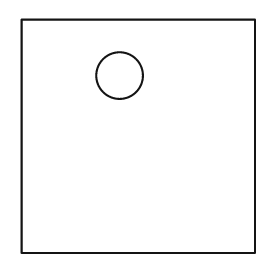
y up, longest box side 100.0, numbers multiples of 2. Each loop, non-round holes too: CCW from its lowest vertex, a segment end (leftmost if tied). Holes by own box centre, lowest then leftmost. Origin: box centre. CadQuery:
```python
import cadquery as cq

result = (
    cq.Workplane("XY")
    .moveTo(-50.0, -50.0)
    .lineTo(50.0, -50.0)
    .lineTo(50.0, 50.0)
    .lineTo(-50.0, 50.0)
    .close()
    .moveTo(-8.0, 26.0)
    .circle(10.0)
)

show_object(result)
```